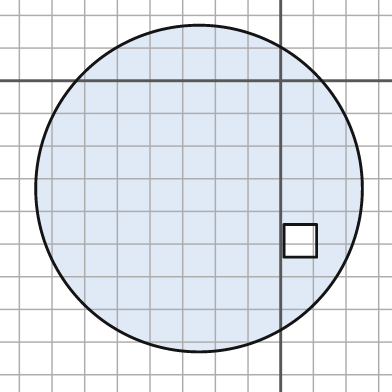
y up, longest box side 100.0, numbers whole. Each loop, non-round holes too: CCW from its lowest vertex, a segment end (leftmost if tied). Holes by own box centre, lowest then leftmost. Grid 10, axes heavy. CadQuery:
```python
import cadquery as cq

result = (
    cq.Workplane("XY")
    .moveTo(-25.0, -33.0)
    .circle(50.0)
    .moveTo(1.0, -54.0)
    .lineTo(11.0, -54.0)
    .lineTo(11.0, -44.0)
    .lineTo(1.0, -44.0)
    .close()
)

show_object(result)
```